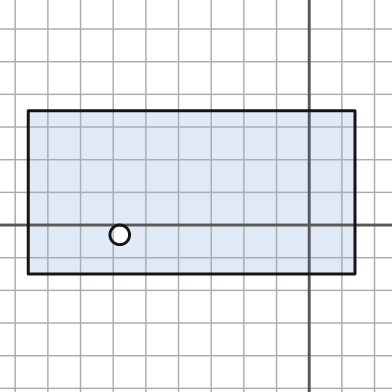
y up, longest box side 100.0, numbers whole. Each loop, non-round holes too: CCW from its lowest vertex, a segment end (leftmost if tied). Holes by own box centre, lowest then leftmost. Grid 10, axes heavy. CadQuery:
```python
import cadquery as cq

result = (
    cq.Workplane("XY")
    .moveTo(-86.0, -15.0)
    .lineTo(14.0, -15.0)
    .lineTo(14.0, 35.0)
    .lineTo(-86.0, 35.0)
    .close()
    .moveTo(-58.0, -3.0)
    .circle(3.0)
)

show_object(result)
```